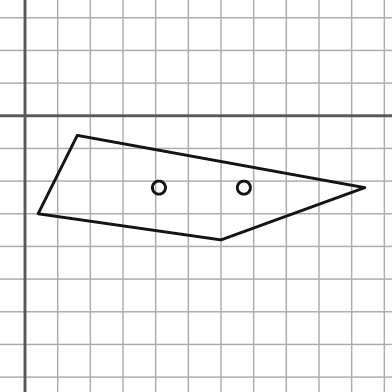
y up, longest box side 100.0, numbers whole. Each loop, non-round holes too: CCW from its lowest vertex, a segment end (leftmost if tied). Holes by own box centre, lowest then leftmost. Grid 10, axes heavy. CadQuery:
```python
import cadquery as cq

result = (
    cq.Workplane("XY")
    .moveTo(60.0, -38.0)
    .lineTo(104.0, -22.0)
    .lineTo(16.0, -6.0)
    .lineTo(4.0, -30.0)
    .close()
    .moveTo(41.0, -22.0)
    .circle(2.0)
    .moveTo(67.0, -22.0)
    .circle(2.0)
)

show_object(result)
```